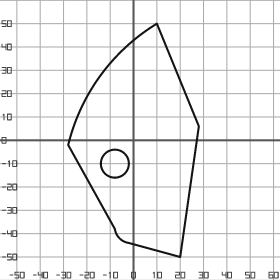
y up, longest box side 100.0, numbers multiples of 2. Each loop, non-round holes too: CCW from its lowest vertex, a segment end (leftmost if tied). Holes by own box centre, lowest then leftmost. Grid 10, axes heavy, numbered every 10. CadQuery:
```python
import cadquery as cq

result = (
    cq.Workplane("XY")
    .moveTo(20.0, -50.0)
    .lineTo(28.0, 6.0)
    .lineTo(10.0, 50.0)
    .threePointArc((-14.0, 28.0), (-28.0, -2.0))
    .lineTo(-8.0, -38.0)
    .threePointArc((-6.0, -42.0), (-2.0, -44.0))
    .close()
    .moveTo(-8.0, -10.0)
    .circle(6.0)
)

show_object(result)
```